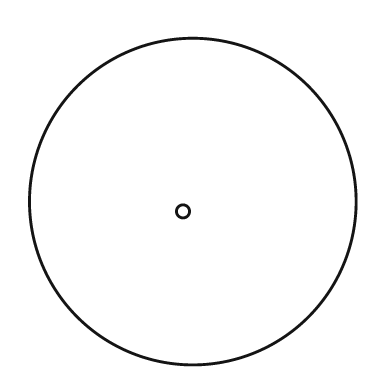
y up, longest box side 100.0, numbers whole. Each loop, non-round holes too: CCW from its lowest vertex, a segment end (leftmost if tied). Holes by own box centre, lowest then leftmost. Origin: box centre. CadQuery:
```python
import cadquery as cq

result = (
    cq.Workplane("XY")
    .moveTo(0.0, 0.0)
    .circle(50.0)
    .moveTo(-3.0, -3.0)
    .circle(2.0)
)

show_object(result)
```